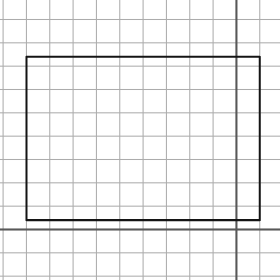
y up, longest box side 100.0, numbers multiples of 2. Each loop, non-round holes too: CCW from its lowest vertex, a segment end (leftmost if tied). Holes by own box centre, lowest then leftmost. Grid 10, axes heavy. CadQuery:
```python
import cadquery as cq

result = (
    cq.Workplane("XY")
    .moveTo(-90.0, 4.0)
    .lineTo(10.0, 4.0)
    .lineTo(10.0, 74.0)
    .lineTo(-90.0, 74.0)
    .close()
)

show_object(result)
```